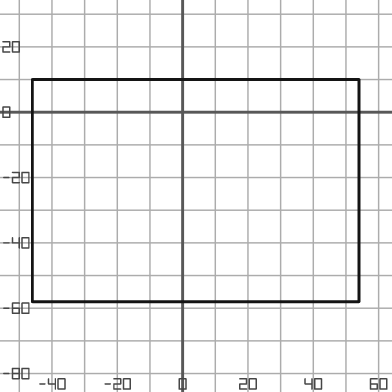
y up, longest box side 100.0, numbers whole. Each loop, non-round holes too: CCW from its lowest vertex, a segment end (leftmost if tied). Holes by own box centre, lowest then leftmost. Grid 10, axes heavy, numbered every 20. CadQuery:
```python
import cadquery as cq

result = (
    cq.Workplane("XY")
    .moveTo(-46.0, -58.0)
    .lineTo(54.0, -58.0)
    .lineTo(54.0, 10.0)
    .lineTo(-46.0, 10.0)
    .close()
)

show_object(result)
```